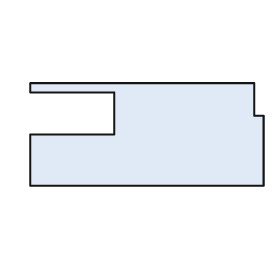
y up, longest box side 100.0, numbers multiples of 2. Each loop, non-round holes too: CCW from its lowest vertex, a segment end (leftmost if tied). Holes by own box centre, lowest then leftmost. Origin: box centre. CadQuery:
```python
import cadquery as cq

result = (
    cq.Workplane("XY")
    .moveTo(-50.0, -22.0)
    .lineTo(50.0, -22.0)
    .lineTo(50.0, 8.0)
    .lineTo(46.0, 8.0)
    .lineTo(46.0, 22.0)
    .lineTo(-50.0, 22.0)
    .lineTo(-50.0, 18.0)
    .lineTo(-14.0, 18.0)
    .lineTo(-14.0, 0.0)
    .lineTo(-50.0, 0.0)
    .close()
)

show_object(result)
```